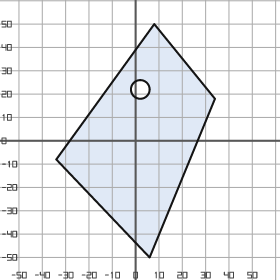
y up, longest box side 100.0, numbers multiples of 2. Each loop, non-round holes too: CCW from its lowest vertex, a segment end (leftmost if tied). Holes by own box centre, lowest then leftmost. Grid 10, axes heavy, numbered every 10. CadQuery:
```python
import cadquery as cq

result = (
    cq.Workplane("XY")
    .moveTo(6.0, -50.0)
    .lineTo(34.0, 18.0)
    .lineTo(8.0, 50.0)
    .lineTo(-34.0, -8.0)
    .close()
    .moveTo(2.0, 22.0)
    .circle(4.0)
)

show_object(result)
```